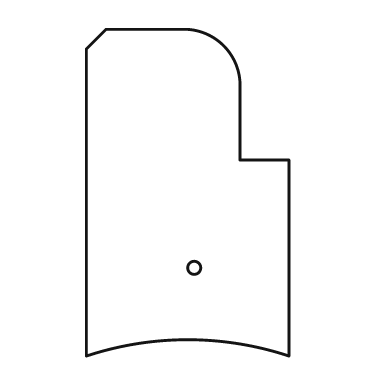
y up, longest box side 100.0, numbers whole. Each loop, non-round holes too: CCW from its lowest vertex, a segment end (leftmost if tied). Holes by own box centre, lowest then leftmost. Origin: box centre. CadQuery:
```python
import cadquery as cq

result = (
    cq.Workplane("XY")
    .moveTo(-31.0, -50.0)
    .threePointArc((0.0, -45.0), (31.0, -50.0))
    .lineTo(31.0, 10.0)
    .lineTo(16.0, 10.0)
    .lineTo(16.0, 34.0)
    .threePointArc((11.0, 45.0), (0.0, 50.0))
    .lineTo(-25.0, 50.0)
    .lineTo(-31.0, 44.0)
    .close()
    .moveTo(2.0, -23.0)
    .circle(2.0)
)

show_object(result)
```